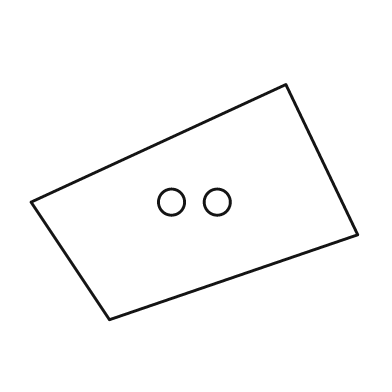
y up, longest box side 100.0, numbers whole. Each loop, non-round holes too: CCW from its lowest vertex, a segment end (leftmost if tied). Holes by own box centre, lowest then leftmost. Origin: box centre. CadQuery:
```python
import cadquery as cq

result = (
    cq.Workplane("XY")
    .moveTo(-26.0, -36.0)
    .lineTo(50.0, -10.0)
    .lineTo(28.0, 36.0)
    .lineTo(-50.0, 0.0)
    .close()
    .moveTo(-7.0, 0.0)
    .circle(4.0)
    .moveTo(7.0, 0.0)
    .circle(4.0)
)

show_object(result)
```